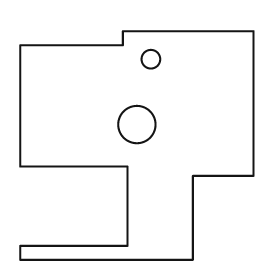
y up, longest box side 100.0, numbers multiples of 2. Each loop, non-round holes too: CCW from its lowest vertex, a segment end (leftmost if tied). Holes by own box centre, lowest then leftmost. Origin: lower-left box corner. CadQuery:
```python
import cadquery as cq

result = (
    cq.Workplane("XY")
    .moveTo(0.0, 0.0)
    .lineTo(74.0, 0.0)
    .lineTo(74.0, 36.0)
    .lineTo(100.0, 36.0)
    .lineTo(100.0, 98.0)
    .lineTo(44.0, 98.0)
    .lineTo(44.0, 92.0)
    .lineTo(0.0, 92.0)
    .lineTo(0.0, 40.0)
    .lineTo(46.0, 40.0)
    .lineTo(46.0, 6.0)
    .lineTo(0.0, 6.0)
    .close()
    .moveTo(50.0, 58.0)
    .circle(8.0)
    .moveTo(56.0, 86.0)
    .circle(4.0)
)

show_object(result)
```